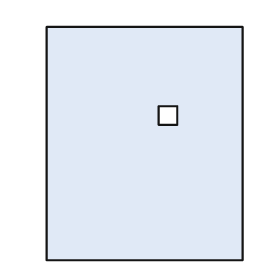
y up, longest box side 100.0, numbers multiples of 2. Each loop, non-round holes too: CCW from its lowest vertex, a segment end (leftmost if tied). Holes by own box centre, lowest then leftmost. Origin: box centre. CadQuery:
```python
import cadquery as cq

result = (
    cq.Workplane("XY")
    .moveTo(-42.0, -50.0)
    .lineTo(42.0, -50.0)
    .lineTo(42.0, 50.0)
    .lineTo(-42.0, 50.0)
    .close()
    .moveTo(6.0, 8.0)
    .lineTo(14.0, 8.0)
    .lineTo(14.0, 16.0)
    .lineTo(6.0, 16.0)
    .close()
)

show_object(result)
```